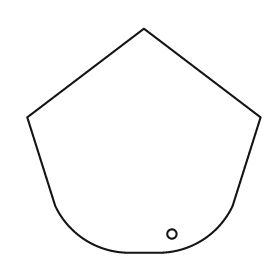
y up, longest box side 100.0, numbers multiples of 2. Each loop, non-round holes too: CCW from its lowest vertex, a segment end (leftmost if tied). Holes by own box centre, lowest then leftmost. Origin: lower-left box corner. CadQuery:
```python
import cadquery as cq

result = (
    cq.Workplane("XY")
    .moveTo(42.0, 0.0)
    .lineTo(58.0, 0.0)
    .threePointArc((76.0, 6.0), (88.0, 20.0))
    .lineTo(100.0, 58.0)
    .lineTo(50.0, 96.0)
    .lineTo(0.0, 58.0)
    .lineTo(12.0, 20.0)
    .threePointArc((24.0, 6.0), (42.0, 0.0))
    .close()
    .moveTo(62.0, 8.0)
    .circle(2.0)
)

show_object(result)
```